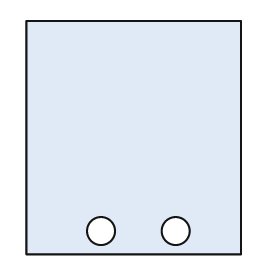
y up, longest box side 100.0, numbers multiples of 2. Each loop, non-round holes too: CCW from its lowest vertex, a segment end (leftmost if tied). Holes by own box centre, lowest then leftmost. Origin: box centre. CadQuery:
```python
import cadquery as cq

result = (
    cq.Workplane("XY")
    .moveTo(-46.0, -50.0)
    .lineTo(46.0, -50.0)
    .lineTo(46.0, 50.0)
    .lineTo(-46.0, 50.0)
    .close()
    .moveTo(-14.0, -40.0)
    .circle(6.0)
    .moveTo(18.0, -40.0)
    .circle(6.0)
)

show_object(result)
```